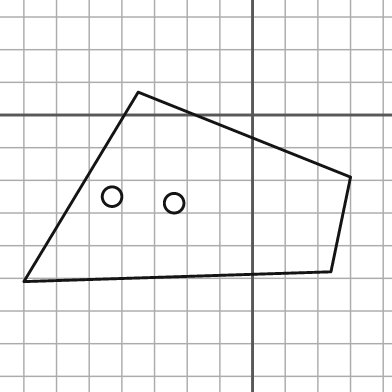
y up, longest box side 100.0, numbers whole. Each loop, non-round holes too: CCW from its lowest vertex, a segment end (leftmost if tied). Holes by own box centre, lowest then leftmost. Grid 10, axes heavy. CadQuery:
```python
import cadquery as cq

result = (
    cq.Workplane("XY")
    .moveTo(-70.0, -51.0)
    .lineTo(24.0, -48.0)
    .lineTo(30.0, -19.0)
    .lineTo(-35.0, 7.0)
    .close()
    .moveTo(-24.0, -27.0)
    .circle(3.0)
    .moveTo(-43.0, -25.0)
    .circle(3.0)
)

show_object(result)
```